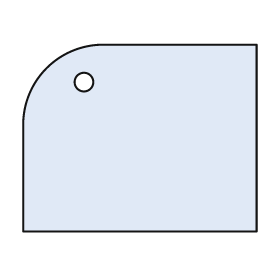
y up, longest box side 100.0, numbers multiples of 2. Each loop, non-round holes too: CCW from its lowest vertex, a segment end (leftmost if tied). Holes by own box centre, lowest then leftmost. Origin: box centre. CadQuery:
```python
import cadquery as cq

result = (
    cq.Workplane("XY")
    .moveTo(-50.0, -40.0)
    .lineTo(50.0, -40.0)
    .lineTo(50.0, 40.0)
    .lineTo(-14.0, 40.0)
    .threePointArc((-40.0, 30.0), (-50.0, 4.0))
    .close()
    .moveTo(-24.0, 24.0)
    .circle(4.0)
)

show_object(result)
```